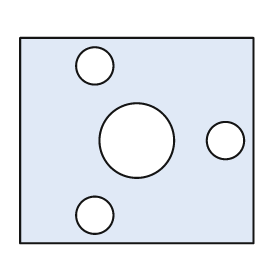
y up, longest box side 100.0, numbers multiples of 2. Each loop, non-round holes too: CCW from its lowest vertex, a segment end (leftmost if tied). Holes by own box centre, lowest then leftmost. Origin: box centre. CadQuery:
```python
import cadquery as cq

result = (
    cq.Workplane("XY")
    .moveTo(-50.0, -44.0)
    .lineTo(50.0, -44.0)
    .lineTo(50.0, 44.0)
    .lineTo(-50.0, 44.0)
    .close()
    .moveTo(-18.0, -32.0)
    .circle(8.0)
    .moveTo(0.0, 0.0)
    .circle(16.0)
    .moveTo(38.0, 0.0)
    .circle(8.0)
    .moveTo(-18.0, 32.0)
    .circle(8.0)
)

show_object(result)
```